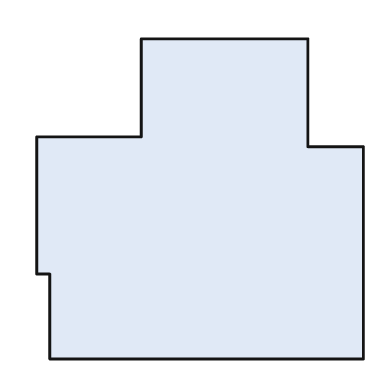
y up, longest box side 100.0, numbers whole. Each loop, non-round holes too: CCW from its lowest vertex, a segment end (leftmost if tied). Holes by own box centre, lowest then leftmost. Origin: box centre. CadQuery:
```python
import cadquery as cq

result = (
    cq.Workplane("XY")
    .moveTo(-46.0, -49.0)
    .lineTo(50.0, -49.0)
    .lineTo(50.0, 16.0)
    .lineTo(33.0, 16.0)
    .lineTo(33.0, 49.0)
    .lineTo(-18.0, 49.0)
    .lineTo(-18.0, 19.0)
    .lineTo(-50.0, 19.0)
    .lineTo(-50.0, -23.0)
    .lineTo(-46.0, -23.0)
    .close()
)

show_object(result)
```